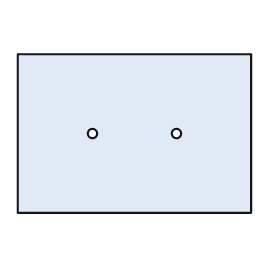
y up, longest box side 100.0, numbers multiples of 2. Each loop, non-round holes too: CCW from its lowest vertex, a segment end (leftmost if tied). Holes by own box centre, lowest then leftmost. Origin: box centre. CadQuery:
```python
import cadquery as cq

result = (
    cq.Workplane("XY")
    .moveTo(-50.0, -34.0)
    .lineTo(50.0, -34.0)
    .lineTo(50.0, 34.0)
    .lineTo(-50.0, 34.0)
    .close()
    .moveTo(-18.0, 0.0)
    .circle(2.0)
    .moveTo(18.0, 0.0)
    .circle(2.0)
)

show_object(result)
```